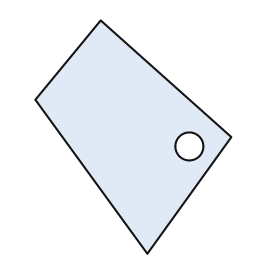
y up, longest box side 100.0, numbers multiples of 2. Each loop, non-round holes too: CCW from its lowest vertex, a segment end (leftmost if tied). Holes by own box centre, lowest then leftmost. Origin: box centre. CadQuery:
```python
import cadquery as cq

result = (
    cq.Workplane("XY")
    .moveTo(6.0, -50.0)
    .lineTo(42.0, 0.0)
    .lineTo(-14.0, 50.0)
    .lineTo(-42.0, 16.0)
    .close()
    .moveTo(24.0, -4.0)
    .circle(6.0)
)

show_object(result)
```